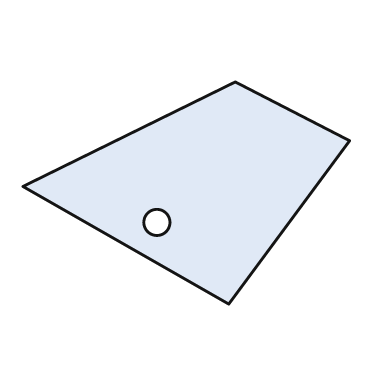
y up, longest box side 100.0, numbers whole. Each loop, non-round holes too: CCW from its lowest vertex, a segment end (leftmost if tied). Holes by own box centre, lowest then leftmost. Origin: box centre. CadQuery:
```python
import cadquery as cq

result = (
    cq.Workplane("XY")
    .moveTo(13.0, -34.0)
    .lineTo(50.0, 16.0)
    .lineTo(15.0, 34.0)
    .lineTo(-50.0, 2.0)
    .close()
    .moveTo(-9.0, -9.0)
    .circle(4.0)
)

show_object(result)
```